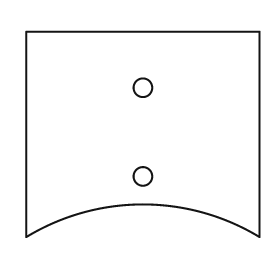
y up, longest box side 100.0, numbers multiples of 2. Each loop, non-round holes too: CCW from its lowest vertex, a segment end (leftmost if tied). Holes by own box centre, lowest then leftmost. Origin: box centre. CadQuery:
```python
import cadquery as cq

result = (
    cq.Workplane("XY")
    .moveTo(-50.0, -44.0)
    .threePointArc((0.0, -30.0), (50.0, -44.0))
    .lineTo(50.0, 44.0)
    .lineTo(-50.0, 44.0)
    .close()
    .moveTo(0.0, -18.0)
    .circle(4.0)
    .moveTo(0.0, 20.0)
    .circle(4.0)
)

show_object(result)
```